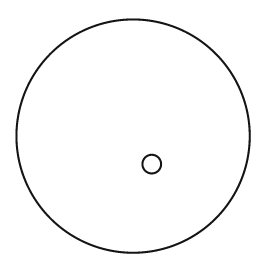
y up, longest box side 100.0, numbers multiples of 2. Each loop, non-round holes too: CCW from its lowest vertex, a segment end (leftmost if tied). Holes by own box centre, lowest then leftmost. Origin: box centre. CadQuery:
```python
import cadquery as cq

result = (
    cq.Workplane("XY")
    .moveTo(0.0, 0.0)
    .circle(50.0)
    .moveTo(8.0, -12.0)
    .circle(4.0)
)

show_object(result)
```